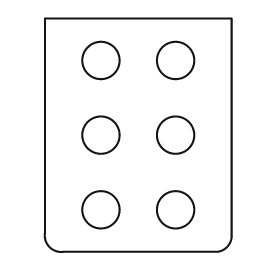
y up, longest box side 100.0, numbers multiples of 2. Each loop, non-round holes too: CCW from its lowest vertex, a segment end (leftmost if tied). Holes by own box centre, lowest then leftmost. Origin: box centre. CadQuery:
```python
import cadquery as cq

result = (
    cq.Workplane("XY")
    .moveTo(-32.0, -50.0)
    .lineTo(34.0, -50.0)
    .threePointArc((38.0, -48.0), (40.0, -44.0))
    .lineTo(40.0, 50.0)
    .lineTo(-40.0, 50.0)
    .lineTo(-40.0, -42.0)
    .threePointArc((-38.0, -48.0), (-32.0, -50.0))
    .close()
    .moveTo(-16.0, -32.0)
    .circle(8.0)
    .moveTo(16.0, -32.0)
    .circle(8.0)
    .moveTo(-16.0, 0.0)
    .circle(8.0)
    .moveTo(16.0, 0.0)
    .circle(8.0)
    .moveTo(-16.0, 32.0)
    .circle(8.0)
    .moveTo(16.0, 32.0)
    .circle(8.0)
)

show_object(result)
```